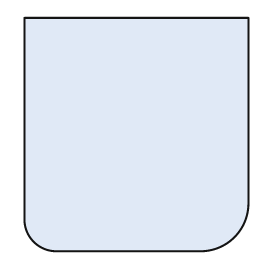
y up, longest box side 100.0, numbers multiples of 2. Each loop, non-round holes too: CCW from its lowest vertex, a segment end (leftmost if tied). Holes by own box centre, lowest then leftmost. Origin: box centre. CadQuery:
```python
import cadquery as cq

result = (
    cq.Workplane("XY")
    .moveTo(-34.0, -50.0)
    .lineTo(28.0, -50.0)
    .threePointArc((42.0, -44.0), (48.0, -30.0))
    .lineTo(48.0, 50.0)
    .lineTo(-48.0, 50.0)
    .lineTo(-48.0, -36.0)
    .threePointArc((-44.0, -46.0), (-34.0, -50.0))
    .close()
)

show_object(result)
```